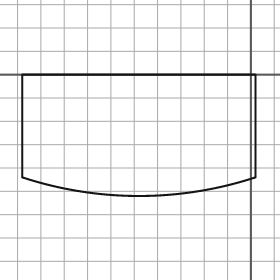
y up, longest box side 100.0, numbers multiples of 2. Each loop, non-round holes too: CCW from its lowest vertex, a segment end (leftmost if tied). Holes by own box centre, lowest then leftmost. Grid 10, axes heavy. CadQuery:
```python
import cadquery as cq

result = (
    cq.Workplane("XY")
    .moveTo(-98.0, -44.0)
    .threePointArc((-48.0, -52.0), (2.0, -44.0))
    .lineTo(2.0, 0.0)
    .lineTo(-98.0, 0.0)
    .close()
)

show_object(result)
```